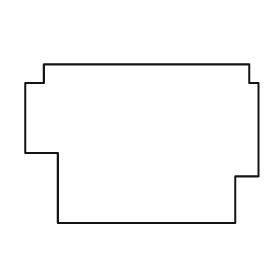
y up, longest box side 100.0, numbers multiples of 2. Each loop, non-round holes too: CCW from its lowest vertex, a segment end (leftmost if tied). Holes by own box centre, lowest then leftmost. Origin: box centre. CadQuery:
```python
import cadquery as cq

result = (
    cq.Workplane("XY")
    .moveTo(-36.0, -34.0)
    .lineTo(40.0, -34.0)
    .lineTo(40.0, -14.0)
    .lineTo(50.0, -14.0)
    .lineTo(50.0, 26.0)
    .lineTo(46.0, 26.0)
    .lineTo(46.0, 34.0)
    .lineTo(-42.0, 34.0)
    .lineTo(-42.0, 26.0)
    .lineTo(-50.0, 26.0)
    .lineTo(-50.0, -4.0)
    .lineTo(-36.0, -4.0)
    .close()
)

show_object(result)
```